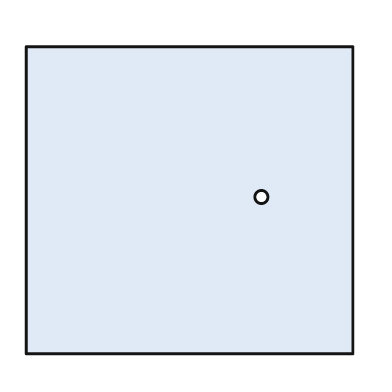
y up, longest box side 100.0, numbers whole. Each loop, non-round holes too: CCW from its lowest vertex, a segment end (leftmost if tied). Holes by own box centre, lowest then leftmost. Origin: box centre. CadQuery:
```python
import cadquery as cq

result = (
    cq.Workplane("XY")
    .moveTo(-50.0, -47.0)
    .lineTo(50.0, -47.0)
    .lineTo(50.0, 47.0)
    .lineTo(-50.0, 47.0)
    .close()
    .moveTo(22.0, 1.0)
    .circle(2.0)
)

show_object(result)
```